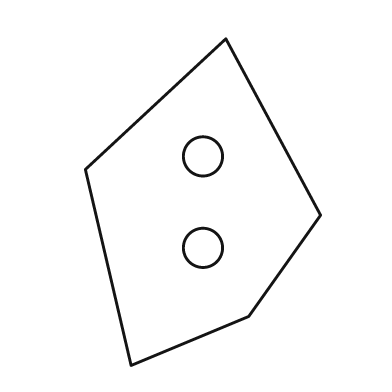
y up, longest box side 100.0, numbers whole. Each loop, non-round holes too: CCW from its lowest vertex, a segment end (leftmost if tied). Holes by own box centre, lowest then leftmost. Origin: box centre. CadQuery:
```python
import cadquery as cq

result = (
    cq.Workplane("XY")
    .moveTo(-22.0, -50.0)
    .lineTo(14.0, -35.0)
    .lineTo(36.0, -4.0)
    .lineTo(7.0, 50.0)
    .lineTo(-36.0, 10.0)
    .close()
    .moveTo(0.0, -14.0)
    .circle(6.0)
    .moveTo(0.0, 14.0)
    .circle(6.0)
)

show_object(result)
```